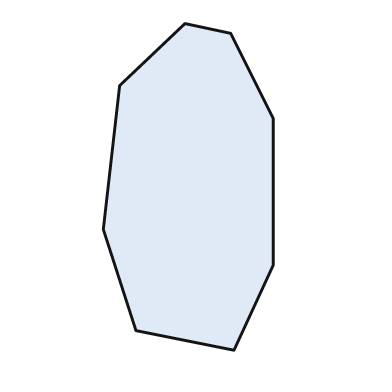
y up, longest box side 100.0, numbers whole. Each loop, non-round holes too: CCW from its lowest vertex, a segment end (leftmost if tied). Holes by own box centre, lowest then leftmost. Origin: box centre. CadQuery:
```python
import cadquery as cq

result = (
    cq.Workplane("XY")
    .moveTo(14.0, -50.0)
    .lineTo(26.0, -24.0)
    .lineTo(26.0, 21.0)
    .lineTo(13.0, 47.0)
    .lineTo(-1.0, 50.0)
    .lineTo(-21.0, 31.0)
    .lineTo(-26.0, -13.0)
    .lineTo(-16.0, -44.0)
    .close()
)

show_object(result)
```